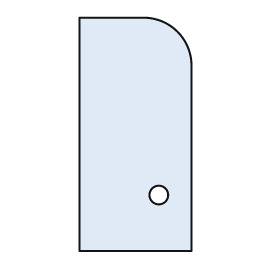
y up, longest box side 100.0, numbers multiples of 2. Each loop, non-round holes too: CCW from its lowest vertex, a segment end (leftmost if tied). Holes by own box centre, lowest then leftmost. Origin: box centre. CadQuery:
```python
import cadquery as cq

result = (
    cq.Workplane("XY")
    .moveTo(-24.0, -50.0)
    .lineTo(24.0, -50.0)
    .lineTo(24.0, 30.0)
    .threePointArc((18.0, 44.0), (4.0, 50.0))
    .lineTo(-24.0, 50.0)
    .close()
    .moveTo(10.0, -26.0)
    .circle(4.0)
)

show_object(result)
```